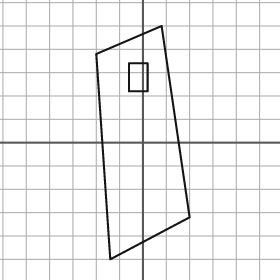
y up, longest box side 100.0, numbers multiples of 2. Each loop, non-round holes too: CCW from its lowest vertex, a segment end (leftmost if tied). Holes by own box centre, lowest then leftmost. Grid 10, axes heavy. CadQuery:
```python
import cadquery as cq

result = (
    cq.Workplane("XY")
    .moveTo(-14.0, -50.0)
    .lineTo(20.0, -32.0)
    .lineTo(8.0, 50.0)
    .lineTo(-20.0, 38.0)
    .close()
    .moveTo(-6.0, 22.0)
    .lineTo(2.0, 22.0)
    .lineTo(2.0, 34.0)
    .lineTo(-6.0, 34.0)
    .close()
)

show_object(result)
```